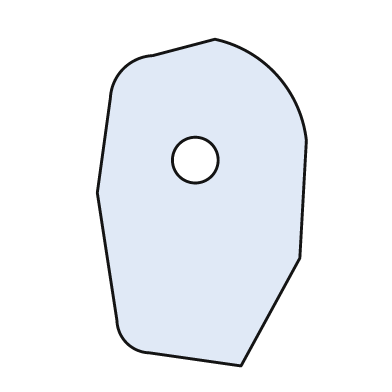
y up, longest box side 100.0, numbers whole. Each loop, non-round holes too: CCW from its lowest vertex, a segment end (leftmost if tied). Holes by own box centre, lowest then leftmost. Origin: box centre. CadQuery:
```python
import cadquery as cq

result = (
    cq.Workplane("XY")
    .moveTo(12.0, -50.0)
    .lineTo(30.0, -17.0)
    .lineTo(32.0, 19.0)
    .threePointArc((23.0, 39.0), (4.0, 50.0))
    .lineTo(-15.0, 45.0)
    .threePointArc((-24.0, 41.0), (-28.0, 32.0))
    .lineTo(-32.0, 3.0)
    .lineTo(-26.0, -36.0)
    .threePointArc((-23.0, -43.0), (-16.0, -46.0))
    .close()
    .moveTo(-2.0, 13.0)
    .circle(7.0)
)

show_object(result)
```